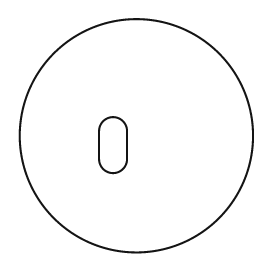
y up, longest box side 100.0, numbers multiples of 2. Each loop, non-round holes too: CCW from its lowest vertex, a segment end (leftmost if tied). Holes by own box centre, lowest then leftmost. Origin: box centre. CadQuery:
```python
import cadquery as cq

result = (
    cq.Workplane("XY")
    .moveTo(0.0, 0.0)
    .circle(50.0)
    .moveTo(-16.0, -10.0)
    .threePointArc((-10.0, -16.0), (-4.0, -10.0))
    .lineTo(-4.0, 2.0)
    .threePointArc((-10.0, 8.0), (-16.0, 2.0))
    .close()
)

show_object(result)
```